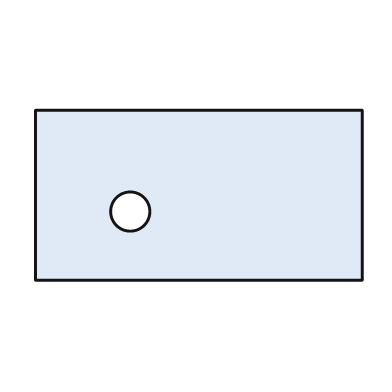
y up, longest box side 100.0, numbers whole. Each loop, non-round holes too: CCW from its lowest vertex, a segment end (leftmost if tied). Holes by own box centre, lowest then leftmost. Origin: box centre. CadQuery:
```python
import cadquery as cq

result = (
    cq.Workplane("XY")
    .moveTo(-50.0, -26.0)
    .lineTo(50.0, -26.0)
    .lineTo(50.0, 26.0)
    .lineTo(-50.0, 26.0)
    .close()
    .moveTo(-21.0, -5.0)
    .circle(6.0)
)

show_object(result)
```